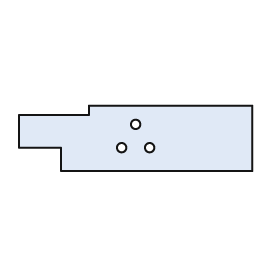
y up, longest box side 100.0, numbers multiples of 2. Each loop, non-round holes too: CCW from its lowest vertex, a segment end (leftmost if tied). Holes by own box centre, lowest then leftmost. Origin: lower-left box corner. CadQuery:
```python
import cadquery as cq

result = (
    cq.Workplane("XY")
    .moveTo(18.0, 0.0)
    .lineTo(100.0, 0.0)
    .lineTo(100.0, 28.0)
    .lineTo(30.0, 28.0)
    .lineTo(30.0, 24.0)
    .lineTo(0.0, 24.0)
    .lineTo(0.0, 10.0)
    .lineTo(18.0, 10.0)
    .close()
    .moveTo(44.0, 10.0)
    .circle(2.0)
    .moveTo(56.0, 10.0)
    .circle(2.0)
    .moveTo(50.0, 20.0)
    .circle(2.0)
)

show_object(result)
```